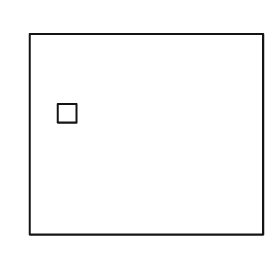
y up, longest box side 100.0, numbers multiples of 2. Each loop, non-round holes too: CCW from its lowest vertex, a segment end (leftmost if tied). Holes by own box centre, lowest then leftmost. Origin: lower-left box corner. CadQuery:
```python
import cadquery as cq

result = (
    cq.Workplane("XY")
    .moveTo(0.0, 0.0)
    .lineTo(100.0, 0.0)
    .lineTo(100.0, 86.0)
    .lineTo(0.0, 86.0)
    .close()
    .moveTo(12.0, 48.0)
    .lineTo(20.0, 48.0)
    .lineTo(20.0, 56.0)
    .lineTo(12.0, 56.0)
    .close()
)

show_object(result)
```